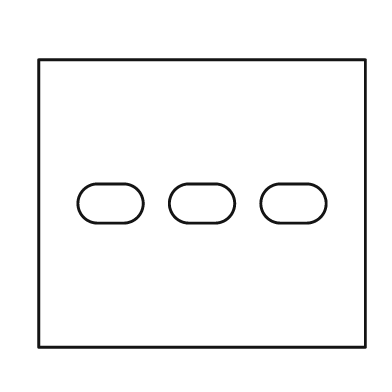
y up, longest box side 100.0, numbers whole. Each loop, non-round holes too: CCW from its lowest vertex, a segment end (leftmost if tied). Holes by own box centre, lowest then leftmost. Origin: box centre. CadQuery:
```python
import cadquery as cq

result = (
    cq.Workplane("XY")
    .moveTo(-50.0, -44.0)
    .lineTo(50.0, -44.0)
    .lineTo(50.0, 44.0)
    .lineTo(-50.0, 44.0)
    .close()
    .moveTo(-32.0, -6.0)
    .lineTo(-24.0, -6.0)
    .threePointArc((-18.0, 0.0), (-24.0, 6.0))
    .lineTo(-32.0, 6.0)
    .threePointArc((-38.0, 0.0), (-32.0, -6.0))
    .close()
    .moveTo(-4.0, -6.0)
    .lineTo(4.0, -6.0)
    .threePointArc((10.0, 0.0), (4.0, 6.0))
    .lineTo(-4.0, 6.0)
    .threePointArc((-10.0, 0.0), (-4.0, -6.0))
    .close()
    .moveTo(24.0, -6.0)
    .lineTo(32.0, -6.0)
    .threePointArc((38.0, 0.0), (32.0, 6.0))
    .lineTo(24.0, 6.0)
    .threePointArc((18.0, 0.0), (24.0, -6.0))
    .close()
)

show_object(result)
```